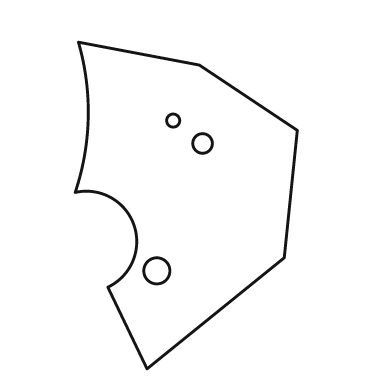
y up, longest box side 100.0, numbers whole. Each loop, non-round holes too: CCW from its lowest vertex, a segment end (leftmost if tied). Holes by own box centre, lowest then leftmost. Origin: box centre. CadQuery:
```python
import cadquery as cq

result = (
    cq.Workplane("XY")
    .moveTo(-12.0, -50.0)
    .lineTo(30.0, -16.0)
    .lineTo(34.0, 23.0)
    .lineTo(4.0, 43.0)
    .lineTo(-33.0, 50.0)
    .threePointArc((-30.0, 27.0), (-34.0, 4.0))
    .threePointArc((-16.0, -6.0), (-24.0, -25.0))
    .close()
    .moveTo(-9.0, -20.0)
    .circle(4.0)
    .moveTo(5.0, 19.0)
    .circle(3.0)
    .moveTo(-4.0, 26.0)
    .circle(2.0)
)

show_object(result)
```